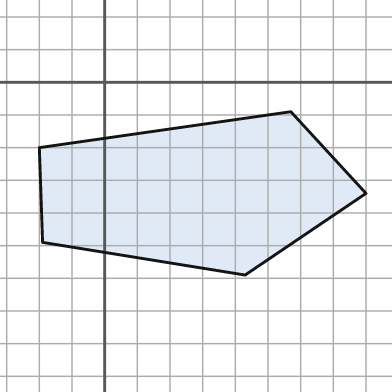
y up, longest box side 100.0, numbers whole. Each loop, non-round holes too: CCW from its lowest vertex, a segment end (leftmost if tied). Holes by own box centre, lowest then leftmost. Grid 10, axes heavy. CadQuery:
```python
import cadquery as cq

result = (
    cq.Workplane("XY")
    .moveTo(43.0, -59.0)
    .lineTo(80.0, -34.0)
    .lineTo(57.0, -9.0)
    .lineTo(-20.0, -20.0)
    .lineTo(-19.0, -49.0)
    .close()
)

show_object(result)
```